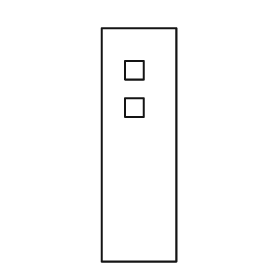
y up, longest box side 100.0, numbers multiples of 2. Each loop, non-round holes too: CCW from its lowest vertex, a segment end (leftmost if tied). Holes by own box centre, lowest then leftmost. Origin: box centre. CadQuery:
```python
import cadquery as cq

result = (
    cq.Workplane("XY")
    .moveTo(-16.0, -50.0)
    .lineTo(16.0, -50.0)
    .lineTo(16.0, 50.0)
    .lineTo(-16.0, 50.0)
    .close()
    .moveTo(-6.0, 12.0)
    .lineTo(2.0, 12.0)
    .lineTo(2.0, 20.0)
    .lineTo(-6.0, 20.0)
    .close()
    .moveTo(-6.0, 28.0)
    .lineTo(2.0, 28.0)
    .lineTo(2.0, 36.0)
    .lineTo(-6.0, 36.0)
    .close()
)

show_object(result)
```